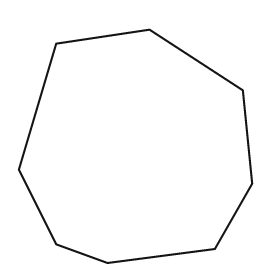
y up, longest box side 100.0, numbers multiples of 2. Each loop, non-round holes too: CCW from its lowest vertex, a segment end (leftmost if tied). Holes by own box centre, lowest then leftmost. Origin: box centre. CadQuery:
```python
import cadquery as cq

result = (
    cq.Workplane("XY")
    .moveTo(-12.0, -50.0)
    .lineTo(34.0, -44.0)
    .lineTo(50.0, -16.0)
    .lineTo(46.0, 24.0)
    .lineTo(6.0, 50.0)
    .lineTo(-34.0, 44.0)
    .lineTo(-50.0, -10.0)
    .lineTo(-34.0, -42.0)
    .close()
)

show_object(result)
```